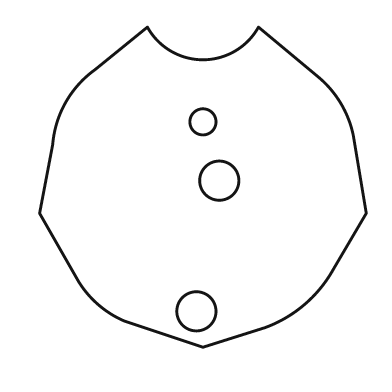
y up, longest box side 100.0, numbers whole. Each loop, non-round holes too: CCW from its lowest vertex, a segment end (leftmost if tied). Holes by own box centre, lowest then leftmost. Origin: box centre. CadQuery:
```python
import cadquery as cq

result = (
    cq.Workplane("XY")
    .moveTo(0.0, -49.0)
    .lineTo(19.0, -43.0)
    .threePointArc((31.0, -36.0), (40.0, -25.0))
    .lineTo(50.0, -8.0)
    .lineTo(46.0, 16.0)
    .threePointArc((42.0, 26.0), (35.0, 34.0))
    .lineTo(17.0, 49.0)
    .threePointArc((0.0, 39.0), (-17.0, 49.0))
    .lineTo(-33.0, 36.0)
    .threePointArc((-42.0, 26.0), (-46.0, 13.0))
    .lineTo(-50.0, -8.0)
    .lineTo(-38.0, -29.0)
    .threePointArc((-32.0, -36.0), (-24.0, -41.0))
    .close()
    .moveTo(-2.0, -38.0)
    .circle(6.0)
    .moveTo(5.0, 2.0)
    .circle(6.0)
    .moveTo(0.0, 20.0)
    .circle(4.0)
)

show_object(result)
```